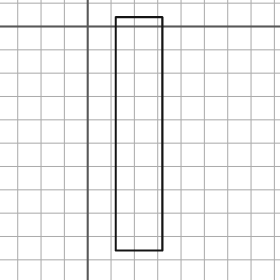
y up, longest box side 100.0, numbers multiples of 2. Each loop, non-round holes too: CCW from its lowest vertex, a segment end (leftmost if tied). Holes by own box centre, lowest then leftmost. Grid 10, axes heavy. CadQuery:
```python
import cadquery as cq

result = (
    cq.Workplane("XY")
    .moveTo(12.0, -96.0)
    .lineTo(32.0, -96.0)
    .lineTo(32.0, 4.0)
    .lineTo(12.0, 4.0)
    .close()
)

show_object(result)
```